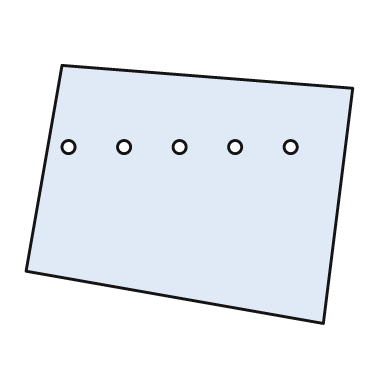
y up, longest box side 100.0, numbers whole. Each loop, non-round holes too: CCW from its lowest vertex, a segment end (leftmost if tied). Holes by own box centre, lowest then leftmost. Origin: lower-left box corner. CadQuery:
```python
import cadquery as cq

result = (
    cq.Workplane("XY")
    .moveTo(91.0, 0.0)
    .lineTo(100.0, 72.0)
    .lineTo(11.0, 79.0)
    .lineTo(0.0, 16.0)
    .close()
    .moveTo(13.0, 54.0)
    .circle(2.0)
    .moveTo(30.0, 54.0)
    .circle(2.0)
    .moveTo(47.0, 54.0)
    .circle(2.0)
    .moveTo(64.0, 54.0)
    .circle(2.0)
    .moveTo(81.0, 54.0)
    .circle(2.0)
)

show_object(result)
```